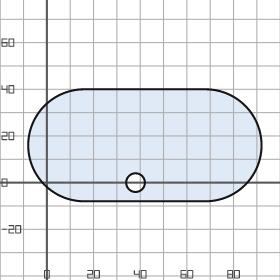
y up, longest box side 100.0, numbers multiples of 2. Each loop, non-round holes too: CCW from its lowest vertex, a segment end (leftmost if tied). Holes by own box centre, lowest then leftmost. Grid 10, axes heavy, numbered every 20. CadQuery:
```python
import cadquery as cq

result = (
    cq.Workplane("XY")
    .moveTo(16.0, -8.0)
    .lineTo(68.0, -8.0)
    .threePointArc((92.0, 16.0), (68.0, 40.0))
    .lineTo(16.0, 40.0)
    .threePointArc((-8.0, 16.0), (16.0, -8.0))
    .close()
    .moveTo(38.0, 0.0)
    .circle(4.0)
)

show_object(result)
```